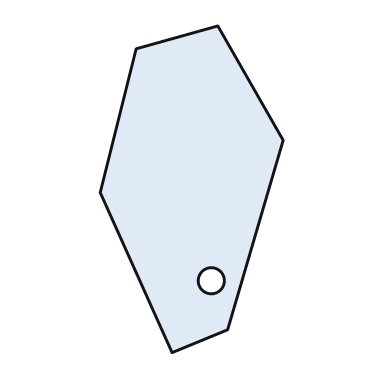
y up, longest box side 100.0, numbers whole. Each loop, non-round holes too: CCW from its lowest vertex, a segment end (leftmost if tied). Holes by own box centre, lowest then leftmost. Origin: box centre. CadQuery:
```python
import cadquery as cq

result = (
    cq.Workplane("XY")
    .moveTo(-6.0, -50.0)
    .lineTo(11.0, -43.0)
    .lineTo(28.0, 15.0)
    .lineTo(8.0, 50.0)
    .lineTo(-17.0, 43.0)
    .lineTo(-28.0, -1.0)
    .close()
    .moveTo(6.0, -28.0)
    .circle(4.0)
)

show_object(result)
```